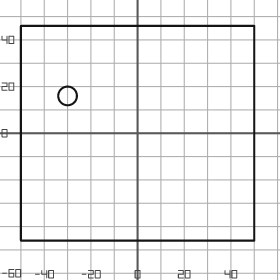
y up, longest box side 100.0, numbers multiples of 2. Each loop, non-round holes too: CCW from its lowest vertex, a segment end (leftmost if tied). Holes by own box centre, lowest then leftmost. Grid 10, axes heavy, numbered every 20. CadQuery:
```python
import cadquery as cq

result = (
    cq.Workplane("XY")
    .moveTo(-50.0, -46.0)
    .lineTo(50.0, -46.0)
    .lineTo(50.0, 46.0)
    .lineTo(-50.0, 46.0)
    .close()
    .moveTo(-30.0, 16.0)
    .circle(4.0)
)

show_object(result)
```